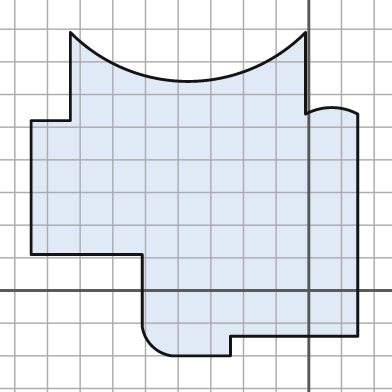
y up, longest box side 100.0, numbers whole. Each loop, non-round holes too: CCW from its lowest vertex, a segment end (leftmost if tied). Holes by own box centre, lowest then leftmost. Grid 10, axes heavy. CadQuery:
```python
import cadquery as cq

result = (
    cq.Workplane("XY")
    .moveTo(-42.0, -20.0)
    .lineTo(-24.0, -20.0)
    .lineTo(-24.0, -14.0)
    .lineTo(15.0, -14.0)
    .lineTo(15.0, 54.0)
    .threePointArc((7.0, 56.0), (-1.0, 54.0))
    .lineTo(-1.0, 79.0)
    .threePointArc((-37.0, 64.0), (-73.0, 79.0))
    .lineTo(-73.0, 52.0)
    .lineTo(-85.0, 52.0)
    .lineTo(-85.0, 11.0)
    .lineTo(-51.0, 11.0)
    .lineTo(-51.0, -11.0)
    .threePointArc((-48.0, -17.0), (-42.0, -20.0))
    .close()
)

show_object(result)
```